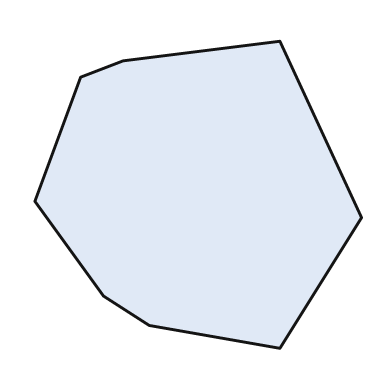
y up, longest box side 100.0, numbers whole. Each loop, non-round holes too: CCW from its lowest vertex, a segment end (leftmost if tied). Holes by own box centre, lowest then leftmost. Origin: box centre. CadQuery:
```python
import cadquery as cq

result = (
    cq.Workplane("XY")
    .moveTo(25.0, -47.0)
    .lineTo(50.0, -7.0)
    .lineTo(25.0, 47.0)
    .lineTo(-23.0, 41.0)
    .lineTo(-36.0, 36.0)
    .lineTo(-50.0, -2.0)
    .lineTo(-29.0, -31.0)
    .lineTo(-15.0, -40.0)
    .close()
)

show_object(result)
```